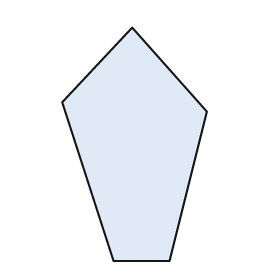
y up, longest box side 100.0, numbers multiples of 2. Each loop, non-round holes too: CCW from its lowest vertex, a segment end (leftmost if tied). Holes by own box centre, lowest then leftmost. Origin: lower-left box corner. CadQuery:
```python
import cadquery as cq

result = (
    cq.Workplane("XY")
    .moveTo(22.0, 0.0)
    .lineTo(46.0, 0.0)
    .lineTo(62.0, 64.0)
    .lineTo(30.0, 100.0)
    .lineTo(0.0, 68.0)
    .close()
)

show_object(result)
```